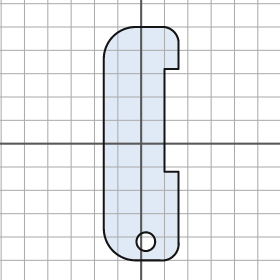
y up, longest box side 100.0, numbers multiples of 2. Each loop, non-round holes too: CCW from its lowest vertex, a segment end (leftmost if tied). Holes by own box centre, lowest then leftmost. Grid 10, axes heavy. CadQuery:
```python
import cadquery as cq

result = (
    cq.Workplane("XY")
    .moveTo(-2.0, -50.0)
    .lineTo(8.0, -50.0)
    .threePointArc((14.0, -48.0), (16.0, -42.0))
    .lineTo(16.0, -12.0)
    .lineTo(10.0, -12.0)
    .lineTo(10.0, 32.0)
    .lineTo(16.0, 32.0)
    .lineTo(16.0, 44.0)
    .threePointArc((14.0, 48.0), (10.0, 50.0))
    .lineTo(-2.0, 50.0)
    .threePointArc((-12.0, 46.0), (-16.0, 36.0))
    .lineTo(-16.0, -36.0)
    .threePointArc((-12.0, -46.0), (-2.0, -50.0))
    .close()
    .moveTo(2.0, -42.0)
    .circle(4.0)
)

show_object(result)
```